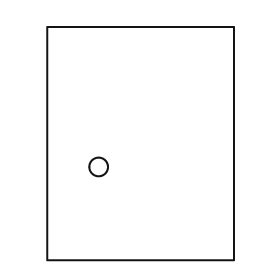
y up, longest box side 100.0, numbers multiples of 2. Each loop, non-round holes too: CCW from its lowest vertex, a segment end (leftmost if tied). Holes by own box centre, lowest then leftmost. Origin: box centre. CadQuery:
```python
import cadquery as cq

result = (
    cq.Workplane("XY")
    .moveTo(-40.0, -50.0)
    .lineTo(40.0, -50.0)
    .lineTo(40.0, 50.0)
    .lineTo(-40.0, 50.0)
    .close()
    .moveTo(-18.0, -10.0)
    .circle(4.0)
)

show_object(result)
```